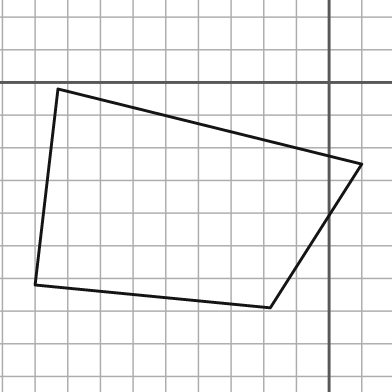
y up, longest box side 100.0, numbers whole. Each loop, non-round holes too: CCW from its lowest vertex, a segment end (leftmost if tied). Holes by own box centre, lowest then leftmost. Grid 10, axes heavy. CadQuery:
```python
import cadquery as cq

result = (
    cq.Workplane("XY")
    .moveTo(-18.0, -69.0)
    .lineTo(10.0, -25.0)
    .lineTo(-83.0, -2.0)
    .lineTo(-90.0, -62.0)
    .close()
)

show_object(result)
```